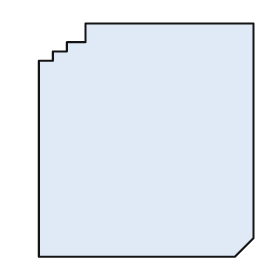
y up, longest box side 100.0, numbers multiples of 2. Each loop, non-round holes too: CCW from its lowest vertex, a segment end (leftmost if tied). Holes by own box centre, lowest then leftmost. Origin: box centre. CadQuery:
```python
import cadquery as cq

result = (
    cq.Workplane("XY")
    .moveTo(-46.0, -50.0)
    .lineTo(38.0, -50.0)
    .lineTo(46.0, -42.0)
    .lineTo(46.0, 50.0)
    .lineTo(-26.0, 50.0)
    .lineTo(-26.0, 42.0)
    .lineTo(-34.0, 42.0)
    .lineTo(-34.0, 38.0)
    .lineTo(-40.0, 38.0)
    .lineTo(-40.0, 34.0)
    .lineTo(-46.0, 34.0)
    .close()
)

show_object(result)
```